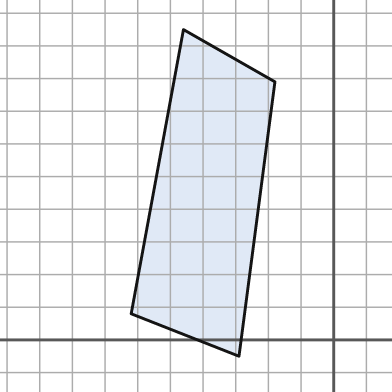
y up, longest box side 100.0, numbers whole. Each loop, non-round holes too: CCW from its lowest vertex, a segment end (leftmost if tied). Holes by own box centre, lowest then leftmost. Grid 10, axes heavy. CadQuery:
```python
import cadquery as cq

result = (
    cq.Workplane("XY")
    .moveTo(-29.0, -5.0)
    .lineTo(-18.0, 79.0)
    .lineTo(-46.0, 95.0)
    .lineTo(-62.0, 8.0)
    .close()
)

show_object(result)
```